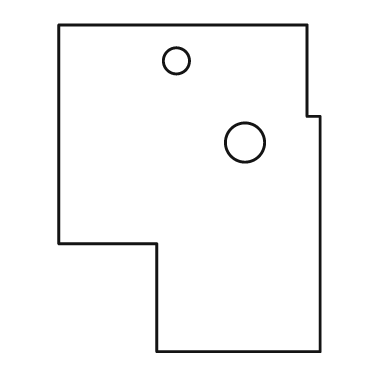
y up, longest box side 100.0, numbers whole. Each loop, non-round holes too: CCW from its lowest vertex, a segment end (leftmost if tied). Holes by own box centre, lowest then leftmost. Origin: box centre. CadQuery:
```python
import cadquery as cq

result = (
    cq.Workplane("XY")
    .moveTo(-10.0, -50.0)
    .lineTo(40.0, -50.0)
    .lineTo(40.0, 22.0)
    .lineTo(36.0, 22.0)
    .lineTo(36.0, 50.0)
    .lineTo(-40.0, 50.0)
    .lineTo(-40.0, -17.0)
    .lineTo(-10.0, -17.0)
    .close()
    .moveTo(17.0, 14.0)
    .circle(6.0)
    .moveTo(-4.0, 39.0)
    .circle(4.0)
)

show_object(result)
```